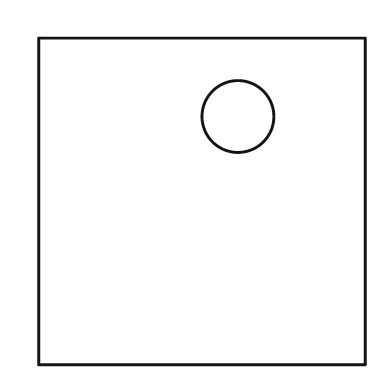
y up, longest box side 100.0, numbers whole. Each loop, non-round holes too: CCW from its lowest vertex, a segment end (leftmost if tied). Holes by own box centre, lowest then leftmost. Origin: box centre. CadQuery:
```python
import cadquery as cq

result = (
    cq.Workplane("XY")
    .moveTo(-50.0, -50.0)
    .lineTo(50.0, -50.0)
    .lineTo(50.0, 50.0)
    .lineTo(-50.0, 50.0)
    .close()
    .moveTo(11.0, 26.0)
    .circle(11.0)
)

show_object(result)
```